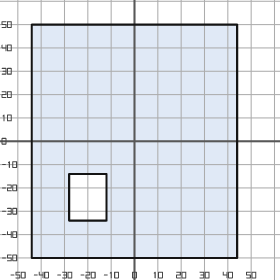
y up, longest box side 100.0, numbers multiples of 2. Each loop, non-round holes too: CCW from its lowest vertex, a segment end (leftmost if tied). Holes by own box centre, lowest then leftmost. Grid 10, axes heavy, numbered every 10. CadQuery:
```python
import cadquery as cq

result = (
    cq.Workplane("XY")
    .moveTo(-44.0, -50.0)
    .lineTo(44.0, -50.0)
    .lineTo(44.0, 50.0)
    .lineTo(-44.0, 50.0)
    .close()
    .moveTo(-28.0, -34.0)
    .lineTo(-12.0, -34.0)
    .lineTo(-12.0, -14.0)
    .lineTo(-28.0, -14.0)
    .close()
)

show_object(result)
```